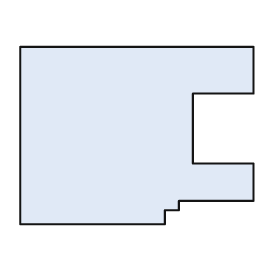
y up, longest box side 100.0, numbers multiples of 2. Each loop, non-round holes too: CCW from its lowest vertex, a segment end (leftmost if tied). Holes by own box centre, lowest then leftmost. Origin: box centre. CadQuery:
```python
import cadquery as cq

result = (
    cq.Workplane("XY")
    .moveTo(-50.0, -38.0)
    .lineTo(12.0, -38.0)
    .lineTo(12.0, -32.0)
    .lineTo(18.0, -32.0)
    .lineTo(18.0, -28.0)
    .lineTo(50.0, -28.0)
    .lineTo(50.0, -12.0)
    .lineTo(24.0, -12.0)
    .lineTo(24.0, 18.0)
    .lineTo(50.0, 18.0)
    .lineTo(50.0, 38.0)
    .lineTo(-50.0, 38.0)
    .close()
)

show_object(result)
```